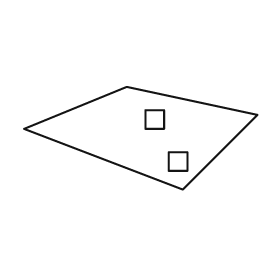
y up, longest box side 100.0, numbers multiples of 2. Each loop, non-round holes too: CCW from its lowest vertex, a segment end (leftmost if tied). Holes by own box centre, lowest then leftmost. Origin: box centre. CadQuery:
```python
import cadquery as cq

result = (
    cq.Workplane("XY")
    .moveTo(18.0, -22.0)
    .lineTo(50.0, 10.0)
    .lineTo(-6.0, 22.0)
    .lineTo(-50.0, 4.0)
    .close()
    .moveTo(12.0, -14.0)
    .lineTo(20.0, -14.0)
    .lineTo(20.0, -6.0)
    .lineTo(12.0, -6.0)
    .close()
    .moveTo(2.0, 4.0)
    .lineTo(10.0, 4.0)
    .lineTo(10.0, 12.0)
    .lineTo(2.0, 12.0)
    .close()
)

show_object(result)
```